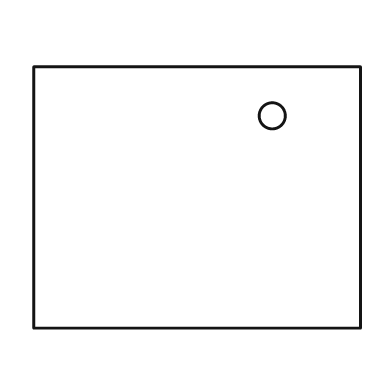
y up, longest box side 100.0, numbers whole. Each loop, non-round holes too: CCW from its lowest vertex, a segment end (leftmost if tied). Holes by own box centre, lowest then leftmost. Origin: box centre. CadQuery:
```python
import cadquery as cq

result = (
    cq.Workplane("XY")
    .moveTo(-50.0, -40.0)
    .lineTo(50.0, -40.0)
    .lineTo(50.0, 40.0)
    .lineTo(-50.0, 40.0)
    .close()
    .moveTo(23.0, 25.0)
    .circle(4.0)
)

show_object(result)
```